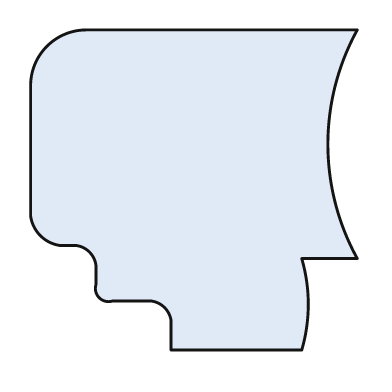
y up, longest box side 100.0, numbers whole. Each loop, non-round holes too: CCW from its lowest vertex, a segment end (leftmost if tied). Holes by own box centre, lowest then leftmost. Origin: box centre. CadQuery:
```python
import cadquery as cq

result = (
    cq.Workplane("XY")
    .moveTo(-7.0, -49.0)
    .lineTo(33.0, -49.0)
    .threePointArc((35.0, -35.0), (33.0, -21.0))
    .lineTo(50.0, -21.0)
    .threePointArc((41.0, 14.0), (50.0, 49.0))
    .lineTo(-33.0, 49.0)
    .threePointArc((-45.0, 44.0), (-50.0, 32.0))
    .lineTo(-50.0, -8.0)
    .threePointArc((-47.0, -14.0), (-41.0, -17.0))
    .lineTo(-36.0, -17.0)
    .threePointArc((-32.0, -19.0), (-30.0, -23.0))
    .lineTo(-30.0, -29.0)
    .threePointArc((-29.0, -33.0), (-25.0, -34.0))
    .lineTo(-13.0, -34.0)
    .threePointArc((-9.0, -36.0), (-7.0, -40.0))
    .close()
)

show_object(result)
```